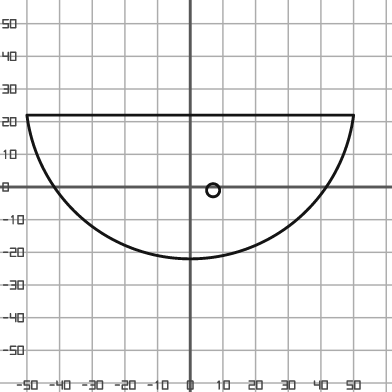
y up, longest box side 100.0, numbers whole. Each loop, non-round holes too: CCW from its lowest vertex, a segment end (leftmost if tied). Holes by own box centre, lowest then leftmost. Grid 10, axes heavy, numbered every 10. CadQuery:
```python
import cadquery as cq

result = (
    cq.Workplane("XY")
    .moveTo(-50.0, 22.0)
    .threePointArc((0.0, -22.0), (50.0, 22.0))
    .close()
    .moveTo(7.0, -1.0)
    .circle(2.0)
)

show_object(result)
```